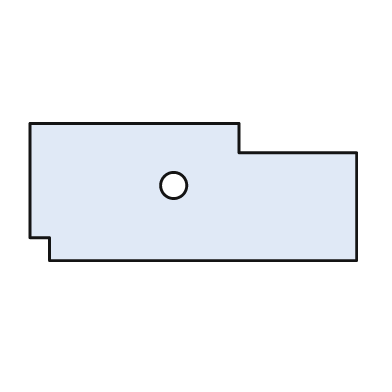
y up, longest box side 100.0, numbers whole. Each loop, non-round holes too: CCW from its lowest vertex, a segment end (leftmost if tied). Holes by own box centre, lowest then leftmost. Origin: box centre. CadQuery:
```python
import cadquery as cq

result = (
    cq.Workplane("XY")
    .moveTo(-44.0, -21.0)
    .lineTo(50.0, -21.0)
    .lineTo(50.0, 12.0)
    .lineTo(14.0, 12.0)
    .lineTo(14.0, 21.0)
    .lineTo(-50.0, 21.0)
    .lineTo(-50.0, -14.0)
    .lineTo(-44.0, -14.0)
    .close()
    .moveTo(-6.0, 2.0)
    .circle(4.0)
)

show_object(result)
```